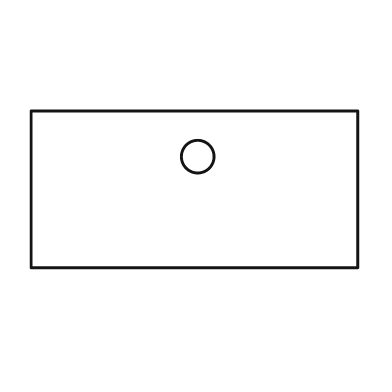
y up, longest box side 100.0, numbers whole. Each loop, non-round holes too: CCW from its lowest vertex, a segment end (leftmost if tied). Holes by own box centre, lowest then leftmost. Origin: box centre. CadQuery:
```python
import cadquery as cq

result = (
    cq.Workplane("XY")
    .moveTo(-50.0, -24.0)
    .lineTo(50.0, -24.0)
    .lineTo(50.0, 24.0)
    .lineTo(-50.0, 24.0)
    .close()
    .moveTo(1.0, 10.0)
    .circle(5.0)
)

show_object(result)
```